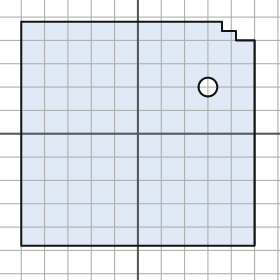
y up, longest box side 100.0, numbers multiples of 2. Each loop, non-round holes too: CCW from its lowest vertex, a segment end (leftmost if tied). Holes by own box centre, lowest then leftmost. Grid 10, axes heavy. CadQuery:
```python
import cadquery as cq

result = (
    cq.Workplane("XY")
    .moveTo(-50.0, -48.0)
    .lineTo(50.0, -48.0)
    .lineTo(50.0, 40.0)
    .lineTo(42.0, 40.0)
    .lineTo(42.0, 44.0)
    .lineTo(36.0, 44.0)
    .lineTo(36.0, 48.0)
    .lineTo(-50.0, 48.0)
    .close()
    .moveTo(30.0, 20.0)
    .circle(4.0)
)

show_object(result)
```